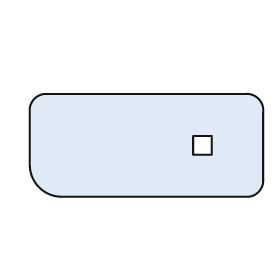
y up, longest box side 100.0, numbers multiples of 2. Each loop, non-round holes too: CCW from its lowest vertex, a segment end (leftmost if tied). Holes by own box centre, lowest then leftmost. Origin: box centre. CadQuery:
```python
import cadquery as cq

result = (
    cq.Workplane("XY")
    .moveTo(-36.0, -22.0)
    .lineTo(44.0, -22.0)
    .threePointArc((48.0, -20.0), (50.0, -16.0))
    .lineTo(50.0, 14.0)
    .threePointArc((48.0, 20.0), (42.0, 22.0))
    .lineTo(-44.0, 22.0)
    .threePointArc((-48.0, 20.0), (-50.0, 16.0))
    .lineTo(-50.0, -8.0)
    .threePointArc((-46.0, -18.0), (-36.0, -22.0))
    .close()
    .moveTo(20.0, -4.0)
    .lineTo(28.0, -4.0)
    .lineTo(28.0, 4.0)
    .lineTo(20.0, 4.0)
    .close()
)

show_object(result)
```